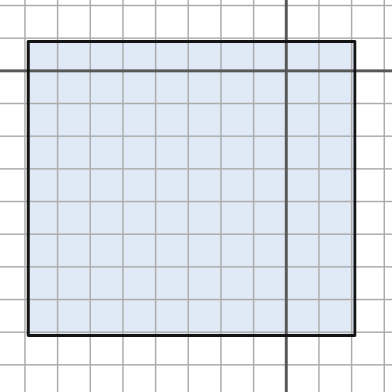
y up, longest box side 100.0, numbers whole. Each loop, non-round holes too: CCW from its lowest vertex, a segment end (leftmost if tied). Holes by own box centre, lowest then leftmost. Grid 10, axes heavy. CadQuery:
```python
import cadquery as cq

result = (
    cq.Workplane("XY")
    .moveTo(-79.0, -81.0)
    .lineTo(21.0, -81.0)
    .lineTo(21.0, 9.0)
    .lineTo(-79.0, 9.0)
    .close()
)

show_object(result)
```